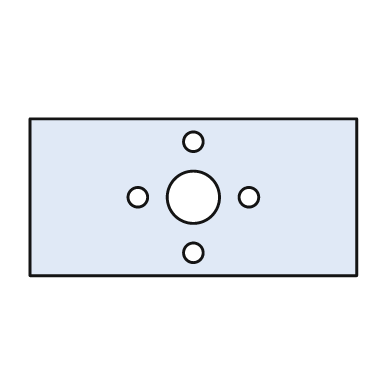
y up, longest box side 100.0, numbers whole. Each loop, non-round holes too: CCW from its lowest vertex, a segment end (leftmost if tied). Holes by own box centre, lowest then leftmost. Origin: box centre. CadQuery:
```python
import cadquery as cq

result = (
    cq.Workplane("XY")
    .moveTo(-50.0, -24.0)
    .lineTo(50.0, -24.0)
    .lineTo(50.0, 24.0)
    .lineTo(-50.0, 24.0)
    .close()
    .moveTo(0.0, -17.0)
    .circle(3.0)
    .moveTo(-17.0, 0.0)
    .circle(3.0)
    .moveTo(0.0, 0.0)
    .circle(8.0)
    .moveTo(17.0, 0.0)
    .circle(3.0)
    .moveTo(0.0, 17.0)
    .circle(3.0)
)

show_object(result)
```